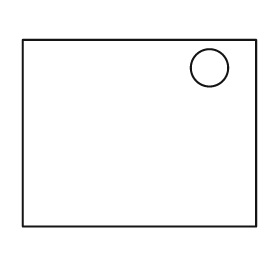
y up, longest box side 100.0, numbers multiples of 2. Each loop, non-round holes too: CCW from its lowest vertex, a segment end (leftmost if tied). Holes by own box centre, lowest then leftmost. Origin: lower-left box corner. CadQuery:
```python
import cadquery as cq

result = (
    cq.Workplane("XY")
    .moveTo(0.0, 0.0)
    .lineTo(100.0, 0.0)
    .lineTo(100.0, 80.0)
    .lineTo(0.0, 80.0)
    .close()
    .moveTo(80.0, 68.0)
    .circle(8.0)
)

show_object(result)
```